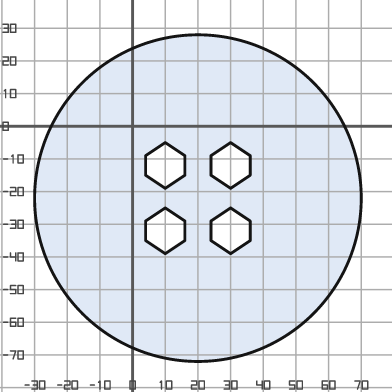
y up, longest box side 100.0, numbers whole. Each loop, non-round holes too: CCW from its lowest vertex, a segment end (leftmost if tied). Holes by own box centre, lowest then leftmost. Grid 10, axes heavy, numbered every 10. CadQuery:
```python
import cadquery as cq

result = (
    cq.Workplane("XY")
    .moveTo(20.0, -22.0)
    .circle(50.0)
    .moveTo(10.0, -39.0)
    .lineTo(16.0, -35.0)
    .lineTo(16.0, -29.0)
    .lineTo(10.0, -25.0)
    .lineTo(4.0, -29.0)
    .lineTo(4.0, -35.0)
    .close()
    .moveTo(30.0, -39.0)
    .lineTo(36.0, -35.0)
    .lineTo(36.0, -29.0)
    .lineTo(30.0, -25.0)
    .lineTo(24.0, -29.0)
    .lineTo(24.0, -35.0)
    .close()
    .moveTo(10.0, -19.0)
    .lineTo(16.0, -15.0)
    .lineTo(16.0, -9.0)
    .lineTo(10.0, -5.0)
    .lineTo(4.0, -9.0)
    .lineTo(4.0, -15.0)
    .close()
    .moveTo(30.0, -19.0)
    .lineTo(36.0, -15.0)
    .lineTo(36.0, -9.0)
    .lineTo(30.0, -5.0)
    .lineTo(24.0, -9.0)
    .lineTo(24.0, -15.0)
    .close()
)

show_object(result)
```